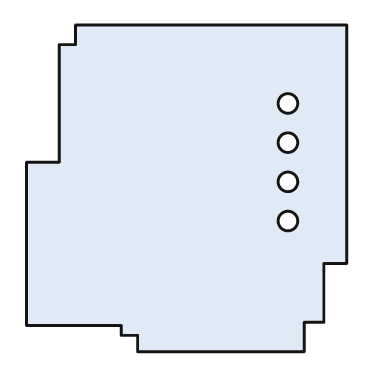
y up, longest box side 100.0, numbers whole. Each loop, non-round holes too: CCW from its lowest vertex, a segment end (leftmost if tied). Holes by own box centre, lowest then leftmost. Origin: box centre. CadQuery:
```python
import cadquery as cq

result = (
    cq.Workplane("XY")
    .moveTo(-15.0, -50.0)
    .lineTo(36.0, -50.0)
    .lineTo(36.0, -41.0)
    .lineTo(42.0, -41.0)
    .lineTo(42.0, -23.0)
    .lineTo(49.0, -23.0)
    .lineTo(49.0, 50.0)
    .lineTo(-34.0, 50.0)
    .lineTo(-34.0, 44.0)
    .lineTo(-39.0, 44.0)
    .lineTo(-39.0, 8.0)
    .lineTo(-49.0, 8.0)
    .lineTo(-49.0, -42.0)
    .lineTo(-20.0, -42.0)
    .lineTo(-20.0, -45.0)
    .lineTo(-15.0, -45.0)
    .close()
    .moveTo(31.0, -10.0)
    .circle(3.0)
    .moveTo(31.0, 2.0)
    .circle(3.0)
    .moveTo(31.0, 14.0)
    .circle(3.0)
    .moveTo(31.0, 26.0)
    .circle(3.0)
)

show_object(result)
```